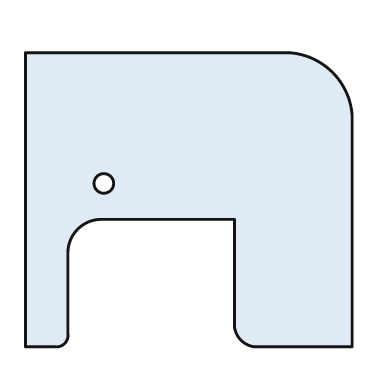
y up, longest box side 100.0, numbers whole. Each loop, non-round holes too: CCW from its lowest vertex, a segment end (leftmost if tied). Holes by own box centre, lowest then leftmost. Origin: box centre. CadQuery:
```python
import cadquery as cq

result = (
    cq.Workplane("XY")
    .moveTo(-50.0, -45.0)
    .lineTo(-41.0, -45.0)
    .threePointArc((-38.0, -44.0), (-37.0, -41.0))
    .lineTo(-37.0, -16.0)
    .threePointArc((-34.0, -9.0), (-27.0, -6.0))
    .lineTo(14.0, -6.0)
    .lineTo(14.0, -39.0)
    .threePointArc((16.0, -43.0), (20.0, -45.0))
    .lineTo(50.0, -45.0)
    .lineTo(50.0, 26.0)
    .threePointArc((44.0, 39.0), (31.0, 45.0))
    .lineTo(-50.0, 45.0)
    .close()
    .moveTo(-26.0, 5.0)
    .circle(3.0)
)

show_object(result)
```